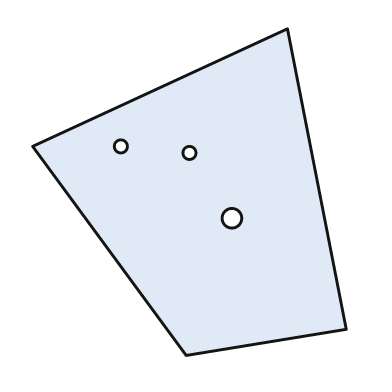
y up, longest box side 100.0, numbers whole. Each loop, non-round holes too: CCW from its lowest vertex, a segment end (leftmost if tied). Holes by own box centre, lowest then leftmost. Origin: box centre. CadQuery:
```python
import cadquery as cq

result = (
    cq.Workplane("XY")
    .moveTo(-1.0, -50.0)
    .lineTo(48.0, -42.0)
    .lineTo(30.0, 50.0)
    .lineTo(-48.0, 14.0)
    .close()
    .moveTo(13.0, -8.0)
    .circle(3.0)
    .moveTo(0.0, 12.0)
    .circle(2.0)
    .moveTo(-21.0, 14.0)
    .circle(2.0)
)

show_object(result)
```